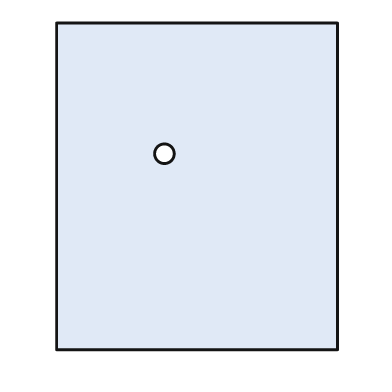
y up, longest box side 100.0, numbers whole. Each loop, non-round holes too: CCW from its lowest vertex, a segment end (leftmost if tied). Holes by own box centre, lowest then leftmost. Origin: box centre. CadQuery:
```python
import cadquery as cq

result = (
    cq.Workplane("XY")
    .moveTo(-43.0, -50.0)
    .lineTo(43.0, -50.0)
    .lineTo(43.0, 50.0)
    .lineTo(-43.0, 50.0)
    .close()
    .moveTo(-10.0, 10.0)
    .circle(3.0)
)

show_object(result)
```